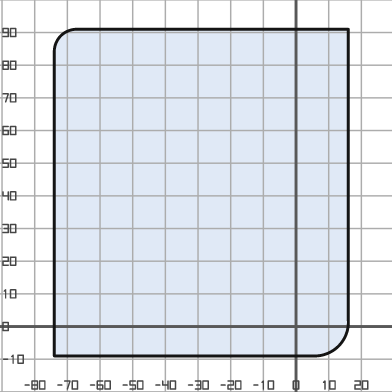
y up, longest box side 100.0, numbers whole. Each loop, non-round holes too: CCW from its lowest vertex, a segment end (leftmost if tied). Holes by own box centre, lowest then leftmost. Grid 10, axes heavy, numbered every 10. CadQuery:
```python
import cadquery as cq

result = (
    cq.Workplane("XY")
    .moveTo(-74.0, -9.0)
    .lineTo(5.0, -9.0)
    .threePointArc((13.0, -6.0), (16.0, 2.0))
    .lineTo(16.0, 91.0)
    .lineTo(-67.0, 91.0)
    .threePointArc((-72.0, 89.0), (-74.0, 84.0))
    .close()
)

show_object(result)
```